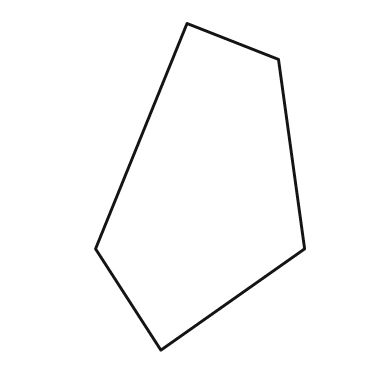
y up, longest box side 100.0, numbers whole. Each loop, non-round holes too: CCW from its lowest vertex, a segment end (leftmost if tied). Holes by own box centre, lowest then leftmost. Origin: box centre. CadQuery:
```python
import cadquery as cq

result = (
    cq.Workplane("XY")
    .moveTo(-12.0, -50.0)
    .lineTo(32.0, -19.0)
    .lineTo(24.0, 39.0)
    .lineTo(-4.0, 50.0)
    .lineTo(-32.0, -19.0)
    .close()
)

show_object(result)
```